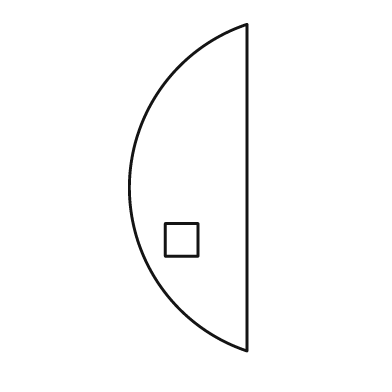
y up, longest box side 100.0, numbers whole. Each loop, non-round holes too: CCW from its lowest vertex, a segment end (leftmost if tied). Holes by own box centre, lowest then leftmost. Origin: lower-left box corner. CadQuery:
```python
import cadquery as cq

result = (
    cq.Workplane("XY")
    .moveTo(36.0, 0.0)
    .lineTo(36.0, 100.0)
    .threePointArc((0.0, 50.0), (36.0, 0.0))
    .close()
    .moveTo(11.0, 29.0)
    .lineTo(21.0, 29.0)
    .lineTo(21.0, 39.0)
    .lineTo(11.0, 39.0)
    .close()
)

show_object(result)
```